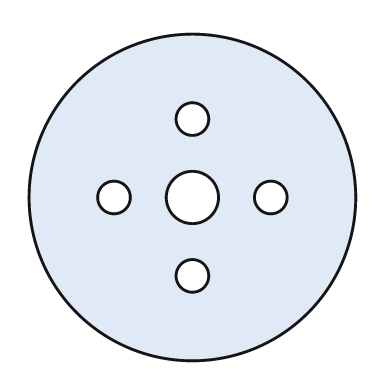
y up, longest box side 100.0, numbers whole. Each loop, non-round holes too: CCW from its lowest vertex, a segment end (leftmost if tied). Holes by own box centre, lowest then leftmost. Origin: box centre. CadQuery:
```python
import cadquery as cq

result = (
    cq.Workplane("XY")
    .moveTo(0.0, 0.0)
    .circle(50.0)
    .moveTo(0.0, -24.0)
    .circle(5.0)
    .moveTo(-24.0, 0.0)
    .circle(5.0)
    .moveTo(0.0, 0.0)
    .circle(8.0)
    .moveTo(24.0, 0.0)
    .circle(5.0)
    .moveTo(0.0, 24.0)
    .circle(5.0)
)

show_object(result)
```